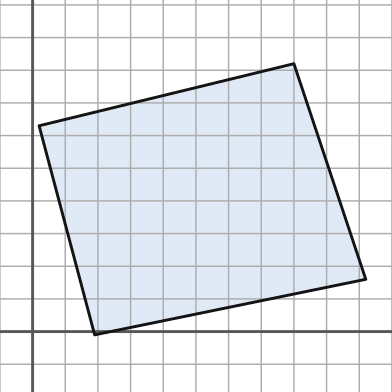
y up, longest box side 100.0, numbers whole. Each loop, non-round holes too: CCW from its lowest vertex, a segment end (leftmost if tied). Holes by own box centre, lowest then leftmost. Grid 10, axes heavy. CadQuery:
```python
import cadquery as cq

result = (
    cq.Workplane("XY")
    .moveTo(19.0, -1.0)
    .lineTo(102.0, 16.0)
    .lineTo(80.0, 82.0)
    .lineTo(2.0, 63.0)
    .close()
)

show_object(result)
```